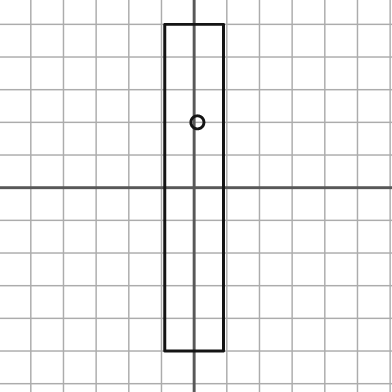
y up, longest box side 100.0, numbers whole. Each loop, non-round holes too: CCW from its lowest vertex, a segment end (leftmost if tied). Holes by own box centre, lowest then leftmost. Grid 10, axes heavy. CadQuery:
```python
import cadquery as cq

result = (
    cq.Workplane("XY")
    .moveTo(-9.0, -50.0)
    .lineTo(9.0, -50.0)
    .lineTo(9.0, 50.0)
    .lineTo(-9.0, 50.0)
    .close()
    .moveTo(1.0, 20.0)
    .circle(2.0)
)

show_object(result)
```